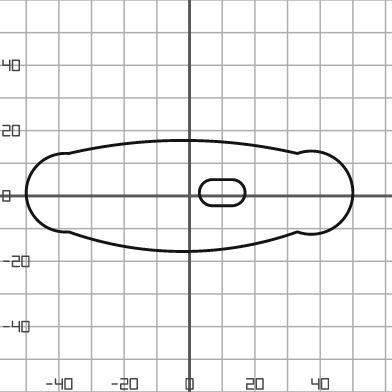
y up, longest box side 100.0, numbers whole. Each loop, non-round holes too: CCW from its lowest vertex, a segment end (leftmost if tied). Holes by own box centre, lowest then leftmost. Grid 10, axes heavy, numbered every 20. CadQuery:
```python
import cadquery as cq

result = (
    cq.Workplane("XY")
    .moveTo(-37.0, -11.0)
    .threePointArc((-2.0, -17.0), (33.0, -11.0))
    .threePointArc((50.0, 1.0), (33.0, 13.0))
    .threePointArc((-2.0, 17.0), (-37.0, 13.0))
    .threePointArc((-50.0, 1.0), (-37.0, -11.0))
    .close()
    .moveTo(7.0, -3.0)
    .lineTo(13.0, -3.0)
    .threePointArc((17.0, 1.0), (13.0, 5.0))
    .lineTo(7.0, 5.0)
    .threePointArc((3.0, 1.0), (7.0, -3.0))
    .close()
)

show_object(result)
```